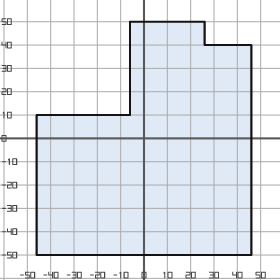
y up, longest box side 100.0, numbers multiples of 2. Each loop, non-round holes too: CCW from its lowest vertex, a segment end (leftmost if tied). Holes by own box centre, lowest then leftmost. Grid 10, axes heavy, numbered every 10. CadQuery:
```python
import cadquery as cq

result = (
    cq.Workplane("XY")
    .moveTo(-46.0, -50.0)
    .lineTo(46.0, -50.0)
    .lineTo(46.0, 40.0)
    .lineTo(26.0, 40.0)
    .lineTo(26.0, 50.0)
    .lineTo(-6.0, 50.0)
    .lineTo(-6.0, 10.0)
    .lineTo(-46.0, 10.0)
    .close()
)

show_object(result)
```